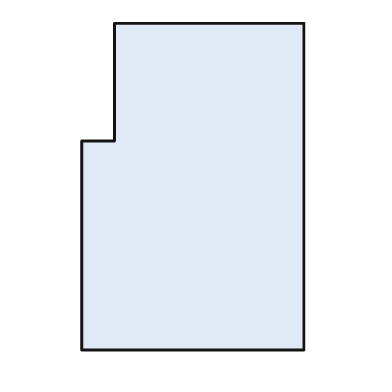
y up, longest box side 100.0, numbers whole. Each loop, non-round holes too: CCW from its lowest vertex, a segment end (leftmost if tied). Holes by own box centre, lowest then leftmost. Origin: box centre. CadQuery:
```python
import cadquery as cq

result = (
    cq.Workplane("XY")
    .moveTo(-34.0, -50.0)
    .lineTo(34.0, -50.0)
    .lineTo(34.0, 50.0)
    .lineTo(-24.0, 50.0)
    .lineTo(-24.0, 14.0)
    .lineTo(-34.0, 14.0)
    .close()
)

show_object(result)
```